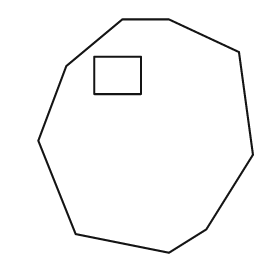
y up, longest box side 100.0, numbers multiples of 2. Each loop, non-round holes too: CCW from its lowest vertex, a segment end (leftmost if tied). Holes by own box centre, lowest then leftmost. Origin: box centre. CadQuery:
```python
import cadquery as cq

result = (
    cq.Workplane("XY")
    .moveTo(10.0, -50.0)
    .lineTo(26.0, -40.0)
    .lineTo(46.0, -8.0)
    .lineTo(40.0, 36.0)
    .lineTo(10.0, 50.0)
    .lineTo(-10.0, 50.0)
    .lineTo(-34.0, 30.0)
    .lineTo(-46.0, -2.0)
    .lineTo(-30.0, -42.0)
    .close()
    .moveTo(-22.0, 18.0)
    .lineTo(-2.0, 18.0)
    .lineTo(-2.0, 34.0)
    .lineTo(-22.0, 34.0)
    .close()
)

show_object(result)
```